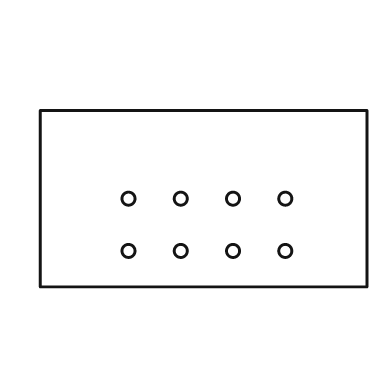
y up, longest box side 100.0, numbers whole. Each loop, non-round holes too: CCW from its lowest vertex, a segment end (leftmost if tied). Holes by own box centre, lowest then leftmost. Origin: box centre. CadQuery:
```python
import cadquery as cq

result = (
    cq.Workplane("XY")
    .moveTo(-50.0, -27.0)
    .lineTo(50.0, -27.0)
    .lineTo(50.0, 27.0)
    .lineTo(-50.0, 27.0)
    .close()
    .moveTo(-23.0, -16.0)
    .circle(2.0)
    .moveTo(-7.0, -16.0)
    .circle(2.0)
    .moveTo(9.0, -16.0)
    .circle(2.0)
    .moveTo(25.0, -16.0)
    .circle(2.0)
    .moveTo(-23.0, 0.0)
    .circle(2.0)
    .moveTo(-7.0, 0.0)
    .circle(2.0)
    .moveTo(9.0, 0.0)
    .circle(2.0)
    .moveTo(25.0, 0.0)
    .circle(2.0)
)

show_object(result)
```